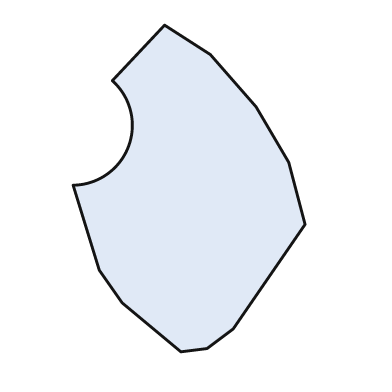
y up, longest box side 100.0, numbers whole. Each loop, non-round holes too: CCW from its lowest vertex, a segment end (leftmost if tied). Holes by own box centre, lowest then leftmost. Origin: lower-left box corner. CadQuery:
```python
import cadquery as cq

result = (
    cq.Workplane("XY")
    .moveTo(33.0, 0.0)
    .lineTo(41.0, 1.0)
    .lineTo(49.0, 7.0)
    .lineTo(71.0, 39.0)
    .lineTo(66.0, 58.0)
    .lineTo(56.0, 75.0)
    .lineTo(42.0, 91.0)
    .lineTo(28.0, 100.0)
    .lineTo(12.0, 83.0)
    .threePointArc((17.0, 63.0), (0.0, 51.0))
    .lineTo(8.0, 25.0)
    .lineTo(15.0, 15.0)
    .close()
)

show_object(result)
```